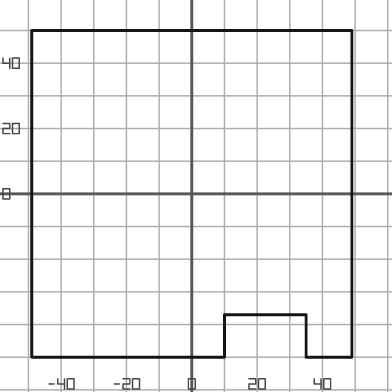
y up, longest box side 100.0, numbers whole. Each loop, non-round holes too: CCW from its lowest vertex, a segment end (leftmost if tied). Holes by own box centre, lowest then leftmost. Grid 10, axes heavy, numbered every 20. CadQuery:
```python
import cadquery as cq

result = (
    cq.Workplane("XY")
    .moveTo(-49.0, -50.0)
    .lineTo(10.0, -50.0)
    .lineTo(10.0, -37.0)
    .lineTo(35.0, -37.0)
    .lineTo(35.0, -50.0)
    .lineTo(49.0, -50.0)
    .lineTo(49.0, 50.0)
    .lineTo(-49.0, 50.0)
    .close()
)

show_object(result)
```